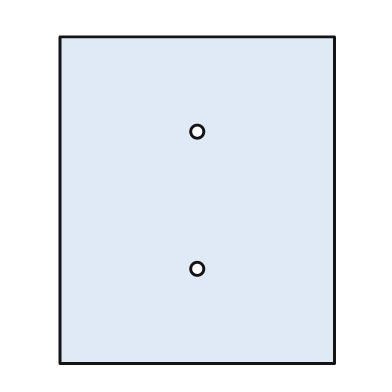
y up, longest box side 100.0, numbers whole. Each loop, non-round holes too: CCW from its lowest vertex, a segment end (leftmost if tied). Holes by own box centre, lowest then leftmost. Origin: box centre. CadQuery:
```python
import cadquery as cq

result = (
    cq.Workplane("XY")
    .moveTo(-42.0, -50.0)
    .lineTo(42.0, -50.0)
    .lineTo(42.0, 50.0)
    .lineTo(-42.0, 50.0)
    .close()
    .moveTo(0.0, -21.0)
    .circle(2.0)
    .moveTo(0.0, 21.0)
    .circle(2.0)
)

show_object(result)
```